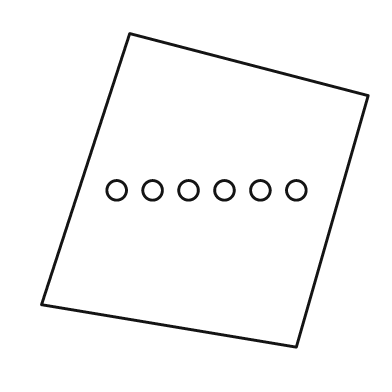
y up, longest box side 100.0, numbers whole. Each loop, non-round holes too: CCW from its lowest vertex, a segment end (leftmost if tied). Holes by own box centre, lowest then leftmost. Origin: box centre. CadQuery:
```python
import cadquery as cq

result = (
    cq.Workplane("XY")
    .moveTo(28.0, -48.0)
    .lineTo(50.0, 29.0)
    .lineTo(-23.0, 48.0)
    .lineTo(-50.0, -35.0)
    .close()
    .moveTo(-27.0, 0.0)
    .circle(3.0)
    .moveTo(-16.0, 0.0)
    .circle(3.0)
    .moveTo(-5.0, 0.0)
    .circle(3.0)
    .moveTo(6.0, 0.0)
    .circle(3.0)
    .moveTo(17.0, 0.0)
    .circle(3.0)
    .moveTo(28.0, 0.0)
    .circle(3.0)
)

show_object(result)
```